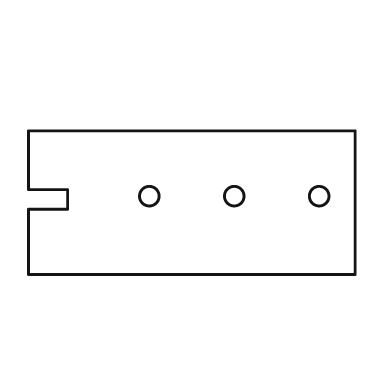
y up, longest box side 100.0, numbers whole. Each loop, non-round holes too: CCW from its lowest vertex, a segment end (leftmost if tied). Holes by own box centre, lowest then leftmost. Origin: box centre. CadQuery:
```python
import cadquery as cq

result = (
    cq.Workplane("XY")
    .moveTo(-50.0, -22.0)
    .lineTo(50.0, -22.0)
    .lineTo(50.0, 22.0)
    .lineTo(-50.0, 22.0)
    .lineTo(-50.0, 4.0)
    .lineTo(-38.0, 4.0)
    .lineTo(-38.0, -2.0)
    .lineTo(-50.0, -2.0)
    .close()
    .moveTo(-13.0, 2.0)
    .circle(3.0)
    .moveTo(13.0, 2.0)
    .circle(3.0)
    .moveTo(39.0, 2.0)
    .circle(3.0)
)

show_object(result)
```